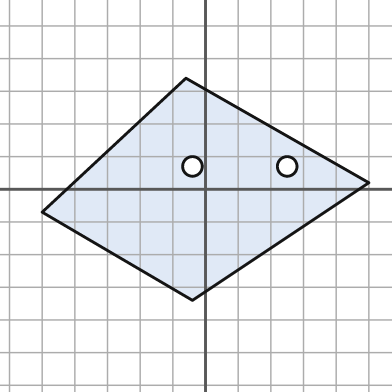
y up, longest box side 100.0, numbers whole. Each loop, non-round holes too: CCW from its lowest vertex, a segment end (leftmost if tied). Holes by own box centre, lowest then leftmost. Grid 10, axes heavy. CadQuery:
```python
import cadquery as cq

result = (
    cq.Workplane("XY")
    .moveTo(-4.0, -34.0)
    .lineTo(50.0, 2.0)
    .lineTo(-6.0, 34.0)
    .lineTo(-50.0, -7.0)
    .close()
    .moveTo(-4.0, 7.0)
    .circle(3.0)
    .moveTo(25.0, 7.0)
    .circle(3.0)
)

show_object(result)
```